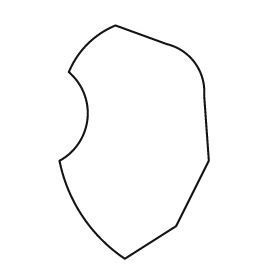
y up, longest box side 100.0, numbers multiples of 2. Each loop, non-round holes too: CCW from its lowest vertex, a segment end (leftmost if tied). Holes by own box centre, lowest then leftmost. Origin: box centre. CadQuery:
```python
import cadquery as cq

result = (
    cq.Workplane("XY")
    .moveTo(-4.0, -50.0)
    .lineTo(18.0, -36.0)
    .lineTo(32.0, -8.0)
    .lineTo(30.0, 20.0)
    .threePointArc((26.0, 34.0), (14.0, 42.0))
    .lineTo(-8.0, 50.0)
    .threePointArc((-20.0, 42.0), (-28.0, 30.0))
    .threePointArc((-20.0, 10.0), (-32.0, -8.0))
    .threePointArc((-22.0, -32.0), (-4.0, -50.0))
    .close()
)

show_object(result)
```